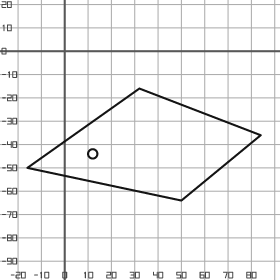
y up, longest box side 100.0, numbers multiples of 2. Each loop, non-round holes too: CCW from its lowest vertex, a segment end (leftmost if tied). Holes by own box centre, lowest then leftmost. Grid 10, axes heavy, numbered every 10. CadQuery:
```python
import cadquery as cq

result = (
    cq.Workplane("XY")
    .moveTo(50.0, -64.0)
    .lineTo(84.0, -36.0)
    .lineTo(32.0, -16.0)
    .lineTo(-16.0, -50.0)
    .close()
    .moveTo(12.0, -44.0)
    .circle(2.0)
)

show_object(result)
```